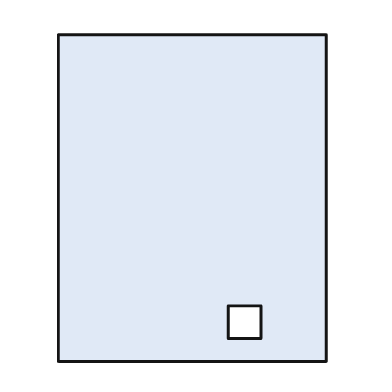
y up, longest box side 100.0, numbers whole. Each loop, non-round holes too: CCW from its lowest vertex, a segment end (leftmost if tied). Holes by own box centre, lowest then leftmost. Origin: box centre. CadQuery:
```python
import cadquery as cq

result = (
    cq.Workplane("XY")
    .moveTo(-41.0, -50.0)
    .lineTo(41.0, -50.0)
    .lineTo(41.0, 50.0)
    .lineTo(-41.0, 50.0)
    .close()
    .moveTo(11.0, -43.0)
    .lineTo(21.0, -43.0)
    .lineTo(21.0, -33.0)
    .lineTo(11.0, -33.0)
    .close()
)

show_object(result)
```